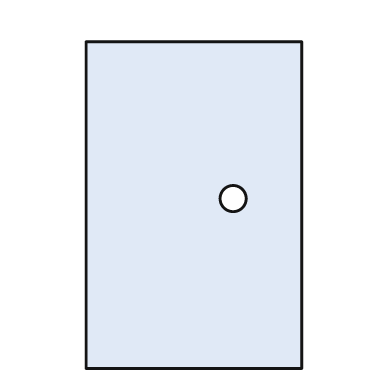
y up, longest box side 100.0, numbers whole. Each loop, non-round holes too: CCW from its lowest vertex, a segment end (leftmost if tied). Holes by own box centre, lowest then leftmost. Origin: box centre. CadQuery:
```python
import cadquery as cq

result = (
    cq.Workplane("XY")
    .moveTo(-33.0, -50.0)
    .lineTo(33.0, -50.0)
    .lineTo(33.0, 50.0)
    .lineTo(-33.0, 50.0)
    .close()
    .moveTo(12.0, 2.0)
    .circle(4.0)
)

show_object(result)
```